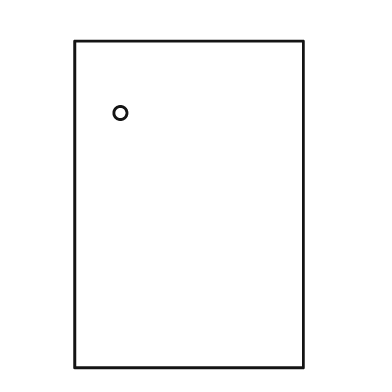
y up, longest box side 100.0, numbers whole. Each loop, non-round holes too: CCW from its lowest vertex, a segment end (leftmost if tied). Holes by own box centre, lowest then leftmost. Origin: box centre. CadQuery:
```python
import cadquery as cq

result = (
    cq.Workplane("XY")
    .moveTo(-35.0, -50.0)
    .lineTo(35.0, -50.0)
    .lineTo(35.0, 50.0)
    .lineTo(-35.0, 50.0)
    .close()
    .moveTo(-21.0, 28.0)
    .circle(2.0)
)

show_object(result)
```